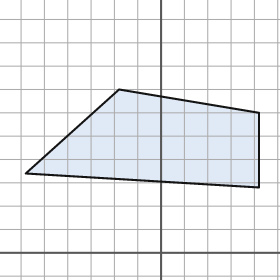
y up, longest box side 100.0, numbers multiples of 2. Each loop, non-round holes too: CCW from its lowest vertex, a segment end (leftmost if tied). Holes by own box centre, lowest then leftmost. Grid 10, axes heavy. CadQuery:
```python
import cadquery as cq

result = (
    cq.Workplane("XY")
    .moveTo(42.0, 28.0)
    .lineTo(42.0, 60.0)
    .lineTo(-18.0, 70.0)
    .lineTo(-58.0, 34.0)
    .close()
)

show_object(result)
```